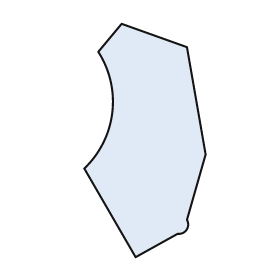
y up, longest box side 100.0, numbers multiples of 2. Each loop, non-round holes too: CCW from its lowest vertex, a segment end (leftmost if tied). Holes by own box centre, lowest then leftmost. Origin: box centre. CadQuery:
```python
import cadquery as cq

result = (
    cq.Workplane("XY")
    .moveTo(-4.0, -50.0)
    .lineTo(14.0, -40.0)
    .threePointArc((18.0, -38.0), (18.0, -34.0))
    .lineTo(26.0, -6.0)
    .lineTo(18.0, 40.0)
    .lineTo(-10.0, 50.0)
    .lineTo(-20.0, 38.0)
    .threePointArc((-14.0, 12.0), (-26.0, -12.0))
    .close()
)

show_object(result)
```